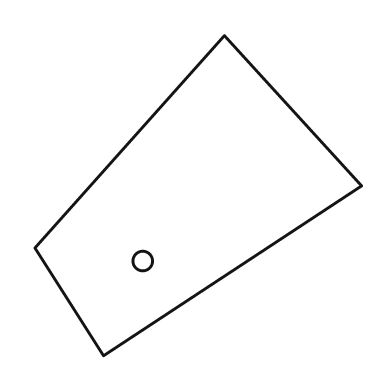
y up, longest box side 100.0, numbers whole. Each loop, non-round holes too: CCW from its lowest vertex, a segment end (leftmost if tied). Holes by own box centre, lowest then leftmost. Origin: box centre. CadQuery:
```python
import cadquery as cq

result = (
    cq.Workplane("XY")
    .moveTo(-29.0, -49.0)
    .lineTo(50.0, 3.0)
    .lineTo(8.0, 49.0)
    .lineTo(-50.0, -16.0)
    .close()
    .moveTo(-17.0, -20.0)
    .circle(3.0)
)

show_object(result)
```